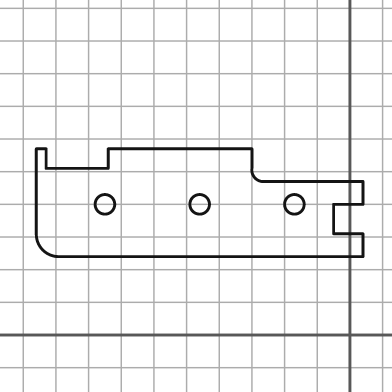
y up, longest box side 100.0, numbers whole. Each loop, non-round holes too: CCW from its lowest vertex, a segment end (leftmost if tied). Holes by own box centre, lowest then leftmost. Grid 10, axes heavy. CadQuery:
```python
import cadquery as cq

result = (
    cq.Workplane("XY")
    .moveTo(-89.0, 24.0)
    .lineTo(4.0, 24.0)
    .lineTo(4.0, 31.0)
    .lineTo(-5.0, 31.0)
    .lineTo(-5.0, 40.0)
    .lineTo(4.0, 40.0)
    .lineTo(4.0, 47.0)
    .lineTo(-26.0, 47.0)
    .threePointArc((-29.0, 48.0), (-30.0, 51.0))
    .lineTo(-30.0, 57.0)
    .lineTo(-74.0, 57.0)
    .lineTo(-74.0, 51.0)
    .lineTo(-93.0, 51.0)
    .lineTo(-93.0, 57.0)
    .lineTo(-96.0, 57.0)
    .lineTo(-96.0, 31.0)
    .threePointArc((-94.0, 26.0), (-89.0, 24.0))
    .close()
    .moveTo(-75.0, 40.0)
    .circle(3.0)
    .moveTo(-46.0, 40.0)
    .circle(3.0)
    .moveTo(-17.0, 40.0)
    .circle(3.0)
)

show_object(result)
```